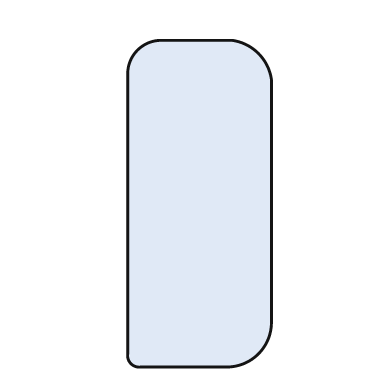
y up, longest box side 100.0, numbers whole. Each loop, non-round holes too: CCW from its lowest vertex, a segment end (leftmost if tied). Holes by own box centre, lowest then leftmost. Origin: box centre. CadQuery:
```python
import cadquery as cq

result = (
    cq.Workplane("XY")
    .moveTo(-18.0, -50.0)
    .lineTo(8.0, -50.0)
    .threePointArc((18.0, -46.0), (22.0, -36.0))
    .lineTo(22.0, 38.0)
    .threePointArc((18.0, 46.0), (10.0, 50.0))
    .lineTo(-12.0, 50.0)
    .threePointArc((-19.0, 47.0), (-22.0, 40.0))
    .lineTo(-22.0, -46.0)
    .threePointArc((-21.0, -49.0), (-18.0, -50.0))
    .close()
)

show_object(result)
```